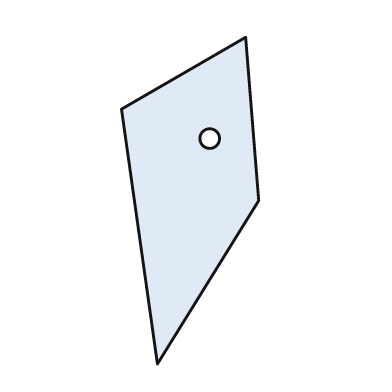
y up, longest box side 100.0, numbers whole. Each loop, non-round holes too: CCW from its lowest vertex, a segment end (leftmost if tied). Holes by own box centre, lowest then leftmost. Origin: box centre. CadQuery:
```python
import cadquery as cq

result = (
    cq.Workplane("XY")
    .moveTo(-10.0, -50.0)
    .lineTo(21.0, 0.0)
    .lineTo(17.0, 50.0)
    .lineTo(-21.0, 28.0)
    .close()
    .moveTo(6.0, 19.0)
    .circle(3.0)
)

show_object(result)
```